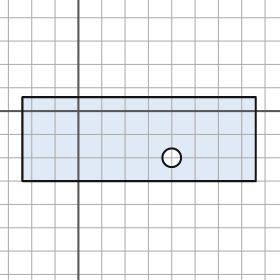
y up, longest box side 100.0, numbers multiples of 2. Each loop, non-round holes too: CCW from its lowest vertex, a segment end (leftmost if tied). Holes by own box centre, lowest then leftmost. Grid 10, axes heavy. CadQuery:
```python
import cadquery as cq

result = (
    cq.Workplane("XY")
    .moveTo(-24.0, -30.0)
    .lineTo(76.0, -30.0)
    .lineTo(76.0, 6.0)
    .lineTo(-24.0, 6.0)
    .close()
    .moveTo(40.0, -20.0)
    .circle(4.0)
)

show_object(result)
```